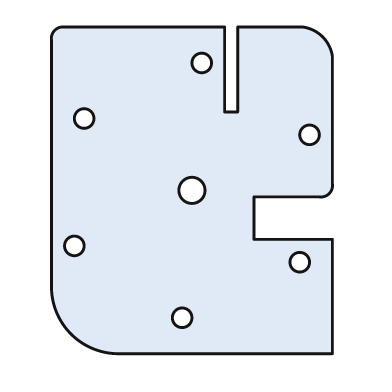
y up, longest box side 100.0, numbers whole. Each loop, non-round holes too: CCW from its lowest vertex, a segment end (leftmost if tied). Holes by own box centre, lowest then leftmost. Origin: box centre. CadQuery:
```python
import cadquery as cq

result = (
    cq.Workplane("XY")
    .moveTo(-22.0, -50.0)
    .lineTo(43.0, -50.0)
    .lineTo(43.0, -15.0)
    .lineTo(19.0, -15.0)
    .lineTo(19.0, -2.0)
    .lineTo(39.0, -2.0)
    .threePointArc((42.0, -1.0), (43.0, 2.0))
    .lineTo(43.0, 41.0)
    .threePointArc((40.0, 47.0), (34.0, 50.0))
    .lineTo(14.0, 50.0)
    .lineTo(14.0, 24.0)
    .lineTo(10.0, 24.0)
    .lineTo(10.0, 50.0)
    .lineTo(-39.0, 50.0)
    .threePointArc((-42.0, 49.0), (-43.0, 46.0))
    .lineTo(-43.0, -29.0)
    .threePointArc((-37.0, -44.0), (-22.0, -50.0))
    .close()
    .moveTo(-3.0, -39.0)
    .circle(3.0)
    .moveTo(33.0, -22.0)
    .circle(3.0)
    .moveTo(-36.0, -17.0)
    .circle(3.0)
    .moveTo(0.0, 0.0)
    .circle(4.0)
    .moveTo(36.0, 17.0)
    .circle(3.0)
    .moveTo(-33.0, 22.0)
    .circle(3.0)
    .moveTo(3.0, 39.0)
    .circle(3.0)
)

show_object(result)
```